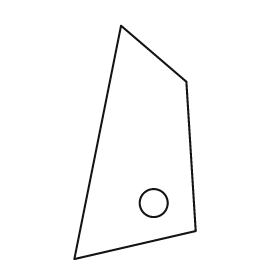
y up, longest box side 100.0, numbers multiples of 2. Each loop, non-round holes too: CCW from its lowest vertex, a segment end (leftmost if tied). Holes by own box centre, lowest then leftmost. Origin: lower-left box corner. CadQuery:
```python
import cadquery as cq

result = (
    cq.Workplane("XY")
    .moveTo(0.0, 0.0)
    .lineTo(52.0, 12.0)
    .lineTo(48.0, 76.0)
    .lineTo(20.0, 100.0)
    .close()
    .moveTo(34.0, 24.0)
    .circle(6.0)
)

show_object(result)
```